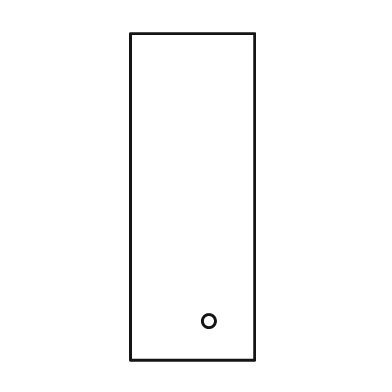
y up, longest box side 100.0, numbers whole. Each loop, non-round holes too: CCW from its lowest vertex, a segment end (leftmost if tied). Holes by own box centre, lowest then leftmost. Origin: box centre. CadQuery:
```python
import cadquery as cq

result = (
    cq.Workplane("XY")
    .moveTo(-19.0, -50.0)
    .lineTo(19.0, -50.0)
    .lineTo(19.0, 50.0)
    .lineTo(-19.0, 50.0)
    .close()
    .moveTo(5.0, -38.0)
    .circle(2.0)
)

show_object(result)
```